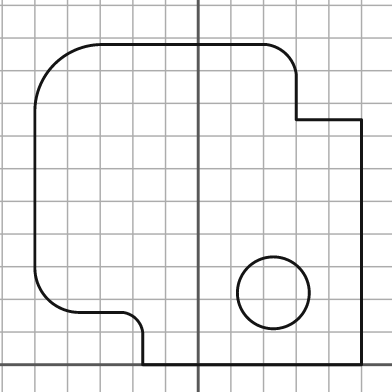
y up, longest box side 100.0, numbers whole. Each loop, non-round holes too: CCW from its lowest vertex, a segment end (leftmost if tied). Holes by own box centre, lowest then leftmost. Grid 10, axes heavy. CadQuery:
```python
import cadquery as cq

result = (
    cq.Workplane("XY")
    .moveTo(-17.0, 0.0)
    .lineTo(50.0, 0.0)
    .lineTo(50.0, 75.0)
    .lineTo(30.0, 75.0)
    .lineTo(30.0, 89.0)
    .threePointArc((27.0, 95.0), (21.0, 98.0))
    .lineTo(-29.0, 98.0)
    .threePointArc((-44.0, 92.0), (-50.0, 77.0))
    .lineTo(-50.0, 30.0)
    .threePointArc((-46.0, 20.0), (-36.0, 16.0))
    .lineTo(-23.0, 16.0)
    .threePointArc((-19.0, 14.0), (-17.0, 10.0))
    .close()
    .moveTo(23.0, 22.0)
    .circle(11.0)
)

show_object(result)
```